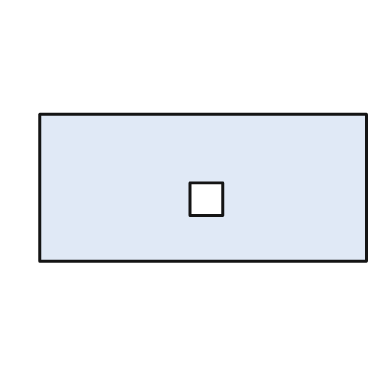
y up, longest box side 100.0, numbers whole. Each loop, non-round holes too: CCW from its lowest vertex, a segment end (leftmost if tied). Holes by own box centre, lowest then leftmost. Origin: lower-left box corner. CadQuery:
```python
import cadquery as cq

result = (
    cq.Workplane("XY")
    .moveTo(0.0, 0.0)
    .lineTo(100.0, 0.0)
    .lineTo(100.0, 45.0)
    .lineTo(0.0, 45.0)
    .close()
    .moveTo(46.0, 14.0)
    .lineTo(56.0, 14.0)
    .lineTo(56.0, 24.0)
    .lineTo(46.0, 24.0)
    .close()
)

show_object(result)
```